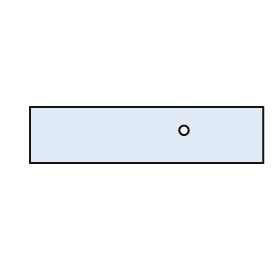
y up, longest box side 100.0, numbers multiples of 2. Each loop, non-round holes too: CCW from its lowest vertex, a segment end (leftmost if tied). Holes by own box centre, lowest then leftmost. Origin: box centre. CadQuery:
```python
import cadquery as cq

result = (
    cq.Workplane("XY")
    .moveTo(-50.0, -12.0)
    .lineTo(50.0, -12.0)
    .lineTo(50.0, 12.0)
    .lineTo(-50.0, 12.0)
    .close()
    .moveTo(16.0, 2.0)
    .circle(2.0)
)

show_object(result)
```